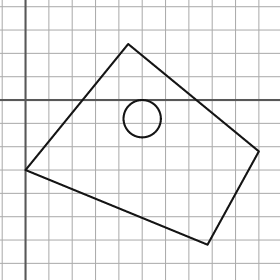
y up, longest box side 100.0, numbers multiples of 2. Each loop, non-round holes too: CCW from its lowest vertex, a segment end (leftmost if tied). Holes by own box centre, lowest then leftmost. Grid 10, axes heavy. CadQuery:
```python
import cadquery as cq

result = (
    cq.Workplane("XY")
    .moveTo(78.0, -62.0)
    .lineTo(100.0, -22.0)
    .lineTo(44.0, 24.0)
    .lineTo(0.0, -30.0)
    .close()
    .moveTo(50.0, -8.0)
    .circle(8.0)
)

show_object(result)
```